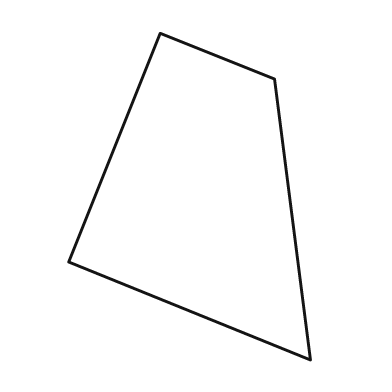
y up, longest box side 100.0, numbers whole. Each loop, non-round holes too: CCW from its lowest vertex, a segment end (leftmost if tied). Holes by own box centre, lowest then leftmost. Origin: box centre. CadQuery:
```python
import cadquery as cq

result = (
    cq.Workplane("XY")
    .moveTo(37.0, -50.0)
    .lineTo(26.0, 36.0)
    .lineTo(-9.0, 50.0)
    .lineTo(-37.0, -20.0)
    .close()
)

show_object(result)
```